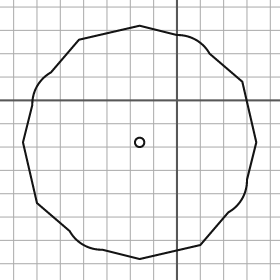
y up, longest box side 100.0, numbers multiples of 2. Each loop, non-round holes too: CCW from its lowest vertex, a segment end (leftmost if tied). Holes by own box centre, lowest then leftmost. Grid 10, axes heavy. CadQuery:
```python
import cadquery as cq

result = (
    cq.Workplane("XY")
    .moveTo(-16.0, -68.0)
    .lineTo(10.0, -62.0)
    .lineTo(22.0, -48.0)
    .threePointArc((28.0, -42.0), (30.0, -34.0))
    .lineTo(34.0, -18.0)
    .lineTo(28.0, 8.0)
    .lineTo(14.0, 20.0)
    .threePointArc((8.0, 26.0), (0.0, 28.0))
    .lineTo(-16.0, 32.0)
    .lineTo(-42.0, 26.0)
    .lineTo(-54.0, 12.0)
    .threePointArc((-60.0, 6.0), (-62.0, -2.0))
    .lineTo(-66.0, -18.0)
    .lineTo(-60.0, -44.0)
    .lineTo(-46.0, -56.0)
    .threePointArc((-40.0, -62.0), (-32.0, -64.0))
    .close()
    .moveTo(-16.0, -18.0)
    .circle(2.0)
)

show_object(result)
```